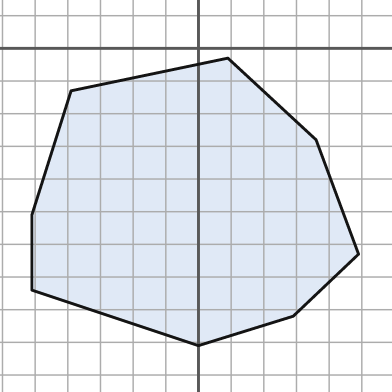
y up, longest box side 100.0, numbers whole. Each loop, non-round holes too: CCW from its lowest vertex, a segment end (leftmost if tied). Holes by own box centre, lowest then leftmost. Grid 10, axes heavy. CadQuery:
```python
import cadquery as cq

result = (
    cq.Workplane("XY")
    .moveTo(0.0, -91.0)
    .lineTo(29.0, -82.0)
    .lineTo(49.0, -63.0)
    .lineTo(36.0, -28.0)
    .lineTo(9.0, -3.0)
    .lineTo(-39.0, -13.0)
    .lineTo(-51.0, -51.0)
    .lineTo(-51.0, -74.0)
    .close()
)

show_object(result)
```